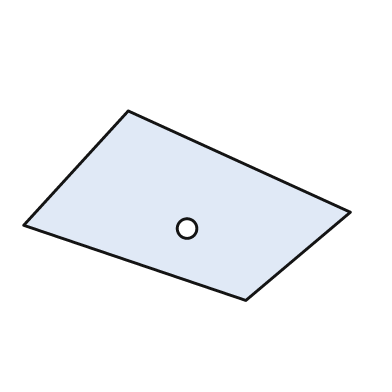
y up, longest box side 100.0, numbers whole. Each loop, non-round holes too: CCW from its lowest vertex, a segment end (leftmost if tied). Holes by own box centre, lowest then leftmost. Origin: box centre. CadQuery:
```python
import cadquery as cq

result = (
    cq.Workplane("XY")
    .moveTo(18.0, -29.0)
    .lineTo(50.0, -2.0)
    .lineTo(-18.0, 29.0)
    .lineTo(-50.0, -6.0)
    .close()
    .moveTo(0.0, -7.0)
    .circle(3.0)
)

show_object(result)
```